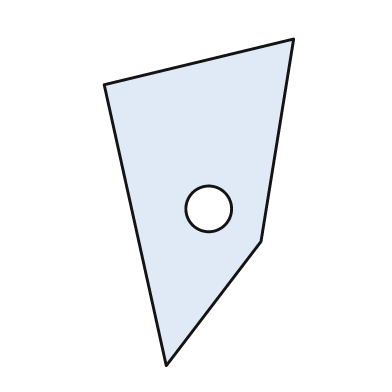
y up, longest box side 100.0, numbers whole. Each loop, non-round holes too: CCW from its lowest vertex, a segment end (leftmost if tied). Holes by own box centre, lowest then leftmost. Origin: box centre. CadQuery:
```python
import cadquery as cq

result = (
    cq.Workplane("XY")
    .moveTo(-10.0, -50.0)
    .lineTo(19.0, -12.0)
    .lineTo(29.0, 50.0)
    .lineTo(-29.0, 36.0)
    .close()
    .moveTo(3.0, -2.0)
    .circle(7.0)
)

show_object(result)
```